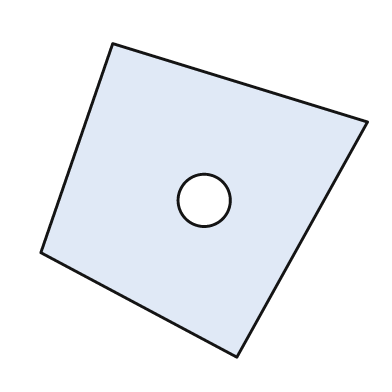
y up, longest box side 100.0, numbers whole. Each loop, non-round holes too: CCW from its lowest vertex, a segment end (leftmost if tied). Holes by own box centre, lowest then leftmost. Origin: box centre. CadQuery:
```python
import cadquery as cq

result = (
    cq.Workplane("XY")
    .moveTo(10.0, -48.0)
    .lineTo(50.0, 24.0)
    .lineTo(-28.0, 48.0)
    .lineTo(-50.0, -16.0)
    .close()
    .moveTo(0.0, 0.0)
    .circle(8.0)
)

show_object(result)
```